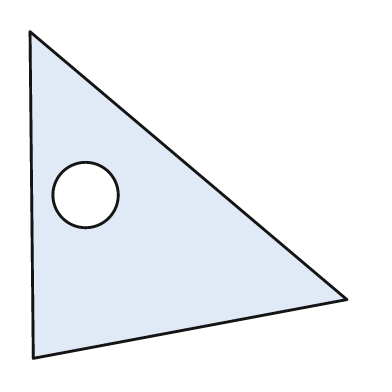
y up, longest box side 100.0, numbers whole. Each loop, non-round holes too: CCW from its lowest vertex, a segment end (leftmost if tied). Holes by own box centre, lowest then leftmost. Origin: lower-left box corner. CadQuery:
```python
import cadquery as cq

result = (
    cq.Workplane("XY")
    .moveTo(1.0, 0.0)
    .lineTo(97.0, 18.0)
    .lineTo(0.0, 100.0)
    .close()
    .moveTo(17.0, 50.0)
    .circle(10.0)
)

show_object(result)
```